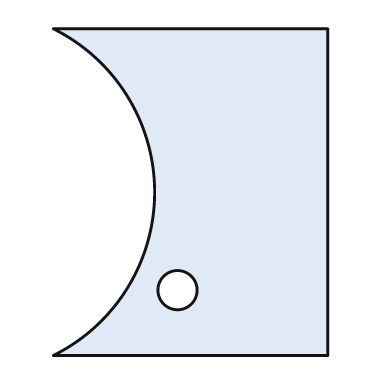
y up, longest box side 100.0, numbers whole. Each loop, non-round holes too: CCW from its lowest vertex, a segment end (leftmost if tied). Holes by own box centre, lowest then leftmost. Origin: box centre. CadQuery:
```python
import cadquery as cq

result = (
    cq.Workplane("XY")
    .moveTo(-42.0, -50.0)
    .lineTo(42.0, -50.0)
    .lineTo(42.0, 50.0)
    .lineTo(-42.0, 50.0)
    .threePointArc((-11.0, 0.0), (-42.0, -50.0))
    .close()
    .moveTo(-4.0, -30.0)
    .circle(6.0)
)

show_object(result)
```